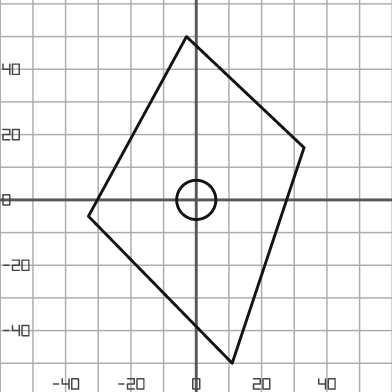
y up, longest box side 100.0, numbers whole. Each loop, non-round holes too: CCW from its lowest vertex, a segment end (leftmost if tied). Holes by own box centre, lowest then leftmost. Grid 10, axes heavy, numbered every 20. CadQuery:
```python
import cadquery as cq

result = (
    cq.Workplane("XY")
    .moveTo(11.0, -50.0)
    .lineTo(33.0, 16.0)
    .lineTo(-3.0, 50.0)
    .lineTo(-33.0, -5.0)
    .close()
    .moveTo(0.0, 0.0)
    .circle(6.0)
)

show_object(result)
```